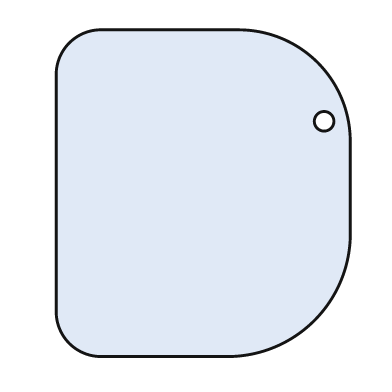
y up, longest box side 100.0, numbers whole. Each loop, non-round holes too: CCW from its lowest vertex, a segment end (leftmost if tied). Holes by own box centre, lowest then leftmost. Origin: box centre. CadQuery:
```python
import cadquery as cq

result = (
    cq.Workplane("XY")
    .moveTo(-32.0, -50.0)
    .lineTo(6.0, -50.0)
    .threePointArc((34.0, -39.0), (45.0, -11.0))
    .lineTo(45.0, 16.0)
    .threePointArc((35.0, 40.0), (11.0, 50.0))
    .lineTo(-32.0, 50.0)
    .threePointArc((-41.0, 46.0), (-45.0, 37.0))
    .lineTo(-45.0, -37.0)
    .threePointArc((-41.0, -46.0), (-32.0, -50.0))
    .close()
    .moveTo(37.0, 22.0)
    .circle(3.0)
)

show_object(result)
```